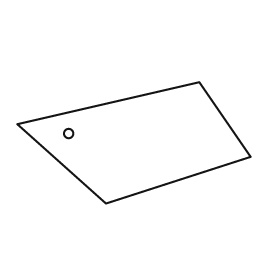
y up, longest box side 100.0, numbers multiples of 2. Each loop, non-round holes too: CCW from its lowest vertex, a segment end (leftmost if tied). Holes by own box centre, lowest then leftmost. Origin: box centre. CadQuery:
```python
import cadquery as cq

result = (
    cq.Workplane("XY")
    .moveTo(-12.0, -26.0)
    .lineTo(50.0, -6.0)
    .lineTo(28.0, 26.0)
    .lineTo(-50.0, 8.0)
    .close()
    .moveTo(-28.0, 4.0)
    .circle(2.0)
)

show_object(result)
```